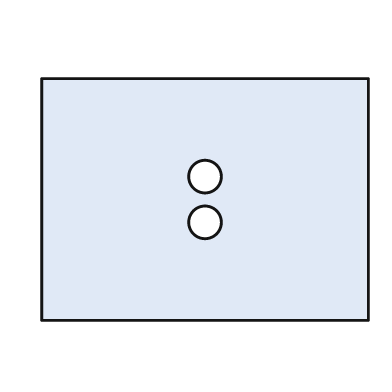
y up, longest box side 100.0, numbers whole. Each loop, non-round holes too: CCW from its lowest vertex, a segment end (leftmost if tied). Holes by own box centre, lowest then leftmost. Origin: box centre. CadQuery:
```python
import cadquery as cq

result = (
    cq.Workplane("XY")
    .moveTo(-50.0, -37.0)
    .lineTo(50.0, -37.0)
    .lineTo(50.0, 37.0)
    .lineTo(-50.0, 37.0)
    .close()
    .moveTo(0.0, -7.0)
    .circle(5.0)
    .moveTo(0.0, 7.0)
    .circle(5.0)
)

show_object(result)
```